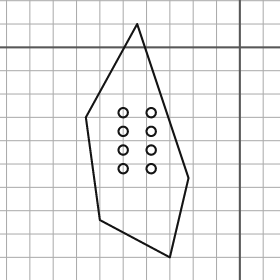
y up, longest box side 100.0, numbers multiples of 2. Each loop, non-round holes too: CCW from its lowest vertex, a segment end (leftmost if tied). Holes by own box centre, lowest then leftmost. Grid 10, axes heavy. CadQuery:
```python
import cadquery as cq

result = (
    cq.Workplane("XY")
    .moveTo(-30.0, -90.0)
    .lineTo(-22.0, -56.0)
    .lineTo(-44.0, 10.0)
    .lineTo(-66.0, -30.0)
    .lineTo(-60.0, -74.0)
    .close()
    .moveTo(-50.0, -52.0)
    .circle(2.0)
    .moveTo(-38.0, -52.0)
    .circle(2.0)
    .moveTo(-50.0, -44.0)
    .circle(2.0)
    .moveTo(-38.0, -44.0)
    .circle(2.0)
    .moveTo(-50.0, -36.0)
    .circle(2.0)
    .moveTo(-38.0, -36.0)
    .circle(2.0)
    .moveTo(-50.0, -28.0)
    .circle(2.0)
    .moveTo(-38.0, -28.0)
    .circle(2.0)
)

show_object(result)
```